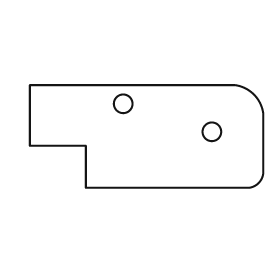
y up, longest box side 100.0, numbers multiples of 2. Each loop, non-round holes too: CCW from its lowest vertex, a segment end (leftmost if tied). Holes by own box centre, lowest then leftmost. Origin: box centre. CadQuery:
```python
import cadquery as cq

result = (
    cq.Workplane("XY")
    .moveTo(-26.0, -22.0)
    .lineTo(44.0, -22.0)
    .threePointArc((48.0, -20.0), (50.0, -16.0))
    .lineTo(50.0, 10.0)
    .threePointArc((46.0, 18.0), (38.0, 22.0))
    .lineTo(-50.0, 22.0)
    .lineTo(-50.0, -4.0)
    .lineTo(-26.0, -4.0)
    .close()
    .moveTo(28.0, 2.0)
    .circle(4.0)
    .moveTo(-10.0, 14.0)
    .circle(4.0)
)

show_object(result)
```